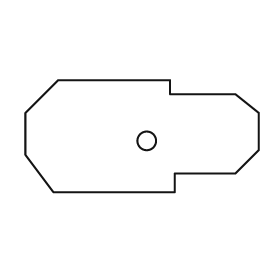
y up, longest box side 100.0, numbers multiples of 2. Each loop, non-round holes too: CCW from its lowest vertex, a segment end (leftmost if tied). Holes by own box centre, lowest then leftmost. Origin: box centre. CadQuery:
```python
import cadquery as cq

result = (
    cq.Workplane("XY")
    .moveTo(-38.0, -24.0)
    .lineTo(14.0, -24.0)
    .lineTo(14.0, -16.0)
    .lineTo(40.0, -16.0)
    .lineTo(50.0, -6.0)
    .lineTo(50.0, 10.0)
    .lineTo(40.0, 18.0)
    .lineTo(12.0, 18.0)
    .lineTo(12.0, 24.0)
    .lineTo(-36.0, 24.0)
    .lineTo(-50.0, 10.0)
    .lineTo(-50.0, -8.0)
    .close()
    .moveTo(2.0, -2.0)
    .circle(4.0)
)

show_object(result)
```